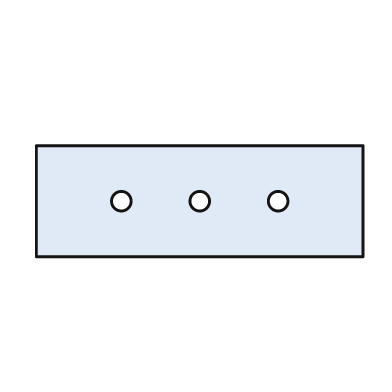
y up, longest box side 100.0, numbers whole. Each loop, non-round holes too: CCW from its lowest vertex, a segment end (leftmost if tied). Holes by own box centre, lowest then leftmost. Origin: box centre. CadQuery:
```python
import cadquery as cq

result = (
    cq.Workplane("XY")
    .moveTo(-50.0, -17.0)
    .lineTo(50.0, -17.0)
    .lineTo(50.0, 17.0)
    .lineTo(-50.0, 17.0)
    .close()
    .moveTo(-24.0, 0.0)
    .circle(3.0)
    .moveTo(0.0, 0.0)
    .circle(3.0)
    .moveTo(24.0, 0.0)
    .circle(3.0)
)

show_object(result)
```